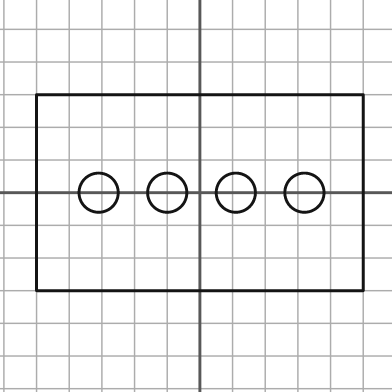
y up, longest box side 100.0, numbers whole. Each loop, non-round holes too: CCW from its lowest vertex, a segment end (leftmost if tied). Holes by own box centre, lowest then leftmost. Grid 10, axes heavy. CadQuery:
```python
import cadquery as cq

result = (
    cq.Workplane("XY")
    .moveTo(-50.0, -30.0)
    .lineTo(50.0, -30.0)
    .lineTo(50.0, 30.0)
    .lineTo(-50.0, 30.0)
    .close()
    .moveTo(-31.0, 0.0)
    .circle(6.0)
    .moveTo(-10.0, 0.0)
    .circle(6.0)
    .moveTo(11.0, 0.0)
    .circle(6.0)
    .moveTo(32.0, 0.0)
    .circle(6.0)
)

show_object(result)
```